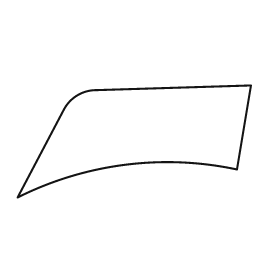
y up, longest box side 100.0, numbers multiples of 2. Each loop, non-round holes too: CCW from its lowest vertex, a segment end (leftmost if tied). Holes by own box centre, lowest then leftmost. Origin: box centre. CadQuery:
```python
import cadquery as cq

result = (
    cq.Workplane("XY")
    .moveTo(-50.0, -24.0)
    .threePointArc((-4.0, -10.0), (44.0, -12.0))
    .lineTo(50.0, 24.0)
    .lineTo(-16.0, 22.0)
    .threePointArc((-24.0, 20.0), (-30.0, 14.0))
    .close()
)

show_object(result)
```